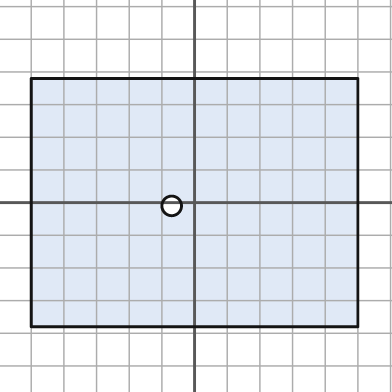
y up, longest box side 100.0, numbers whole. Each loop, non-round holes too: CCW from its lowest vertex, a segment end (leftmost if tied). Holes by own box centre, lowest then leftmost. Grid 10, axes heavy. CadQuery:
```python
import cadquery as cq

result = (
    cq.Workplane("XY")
    .moveTo(-50.0, -38.0)
    .lineTo(50.0, -38.0)
    .lineTo(50.0, 38.0)
    .lineTo(-50.0, 38.0)
    .close()
    .moveTo(-7.0, -1.0)
    .circle(3.0)
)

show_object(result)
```